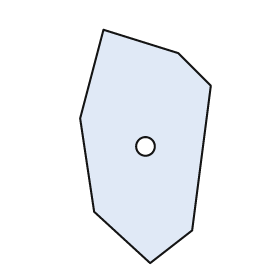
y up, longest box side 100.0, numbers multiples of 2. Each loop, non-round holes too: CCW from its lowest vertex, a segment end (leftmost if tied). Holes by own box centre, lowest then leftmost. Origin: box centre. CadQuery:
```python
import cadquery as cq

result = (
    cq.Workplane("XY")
    .moveTo(2.0, -50.0)
    .lineTo(20.0, -36.0)
    .lineTo(28.0, 26.0)
    .lineTo(14.0, 40.0)
    .lineTo(-18.0, 50.0)
    .lineTo(-28.0, 12.0)
    .lineTo(-22.0, -28.0)
    .close()
    .moveTo(0.0, 0.0)
    .circle(4.0)
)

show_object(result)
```